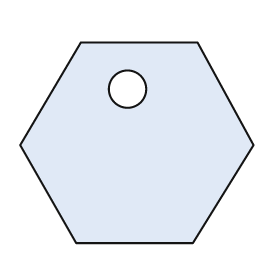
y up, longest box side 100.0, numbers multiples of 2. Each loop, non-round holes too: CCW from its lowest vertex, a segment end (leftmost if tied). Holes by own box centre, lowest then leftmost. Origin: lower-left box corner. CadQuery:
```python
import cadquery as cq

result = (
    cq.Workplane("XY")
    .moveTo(24.0, 0.0)
    .lineTo(74.0, 0.0)
    .lineTo(100.0, 42.0)
    .lineTo(76.0, 86.0)
    .lineTo(26.0, 86.0)
    .lineTo(0.0, 42.0)
    .close()
    .moveTo(46.0, 66.0)
    .circle(8.0)
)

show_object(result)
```